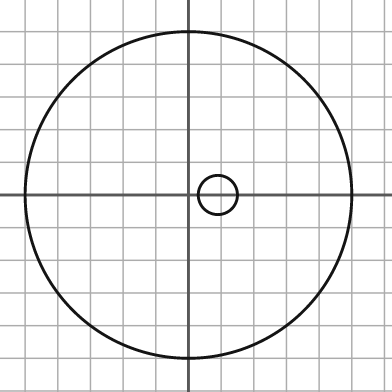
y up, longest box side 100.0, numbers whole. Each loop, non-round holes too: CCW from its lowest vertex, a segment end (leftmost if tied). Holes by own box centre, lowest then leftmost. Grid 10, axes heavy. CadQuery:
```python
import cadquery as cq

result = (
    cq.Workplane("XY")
    .moveTo(0.0, 0.0)
    .circle(50.0)
    .moveTo(9.0, 0.0)
    .circle(6.0)
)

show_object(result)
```